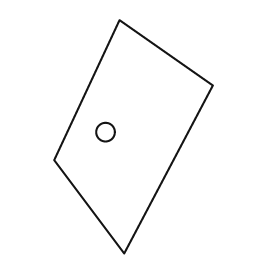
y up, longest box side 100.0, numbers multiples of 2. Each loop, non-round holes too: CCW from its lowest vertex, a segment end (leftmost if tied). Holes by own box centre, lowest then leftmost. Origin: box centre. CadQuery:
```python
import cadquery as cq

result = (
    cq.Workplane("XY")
    .moveTo(-4.0, -50.0)
    .lineTo(34.0, 22.0)
    .lineTo(-6.0, 50.0)
    .lineTo(-34.0, -10.0)
    .close()
    .moveTo(-12.0, 2.0)
    .circle(4.0)
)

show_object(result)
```